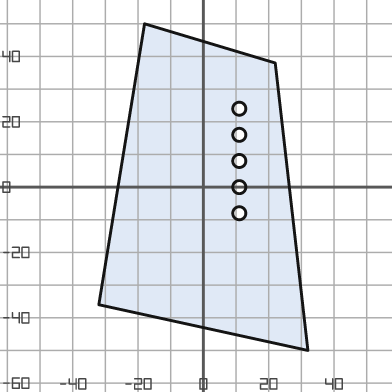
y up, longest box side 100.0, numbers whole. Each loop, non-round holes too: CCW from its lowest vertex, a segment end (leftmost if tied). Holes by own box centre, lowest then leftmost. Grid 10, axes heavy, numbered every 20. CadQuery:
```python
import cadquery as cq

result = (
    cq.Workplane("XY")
    .moveTo(32.0, -50.0)
    .lineTo(22.0, 38.0)
    .lineTo(-18.0, 50.0)
    .lineTo(-32.0, -36.0)
    .close()
    .moveTo(11.0, -8.0)
    .circle(2.0)
    .moveTo(11.0, 0.0)
    .circle(2.0)
    .moveTo(11.0, 8.0)
    .circle(2.0)
    .moveTo(11.0, 16.0)
    .circle(2.0)
    .moveTo(11.0, 24.0)
    .circle(2.0)
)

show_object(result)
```